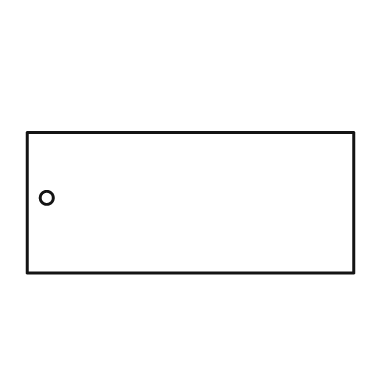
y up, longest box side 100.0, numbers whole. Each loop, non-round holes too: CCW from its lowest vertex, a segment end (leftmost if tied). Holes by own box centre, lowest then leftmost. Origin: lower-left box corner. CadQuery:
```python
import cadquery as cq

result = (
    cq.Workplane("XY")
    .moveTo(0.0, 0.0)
    .lineTo(100.0, 0.0)
    .lineTo(100.0, 43.0)
    .lineTo(0.0, 43.0)
    .close()
    .moveTo(6.0, 23.0)
    .circle(2.0)
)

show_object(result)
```